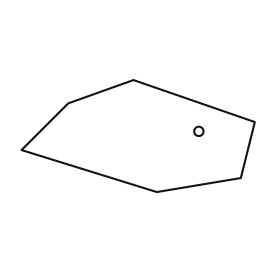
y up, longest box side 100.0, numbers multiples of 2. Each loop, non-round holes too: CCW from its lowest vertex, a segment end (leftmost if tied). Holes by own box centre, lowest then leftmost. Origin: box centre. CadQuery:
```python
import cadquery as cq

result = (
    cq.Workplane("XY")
    .moveTo(8.0, -24.0)
    .lineTo(44.0, -18.0)
    .lineTo(50.0, 6.0)
    .lineTo(-2.0, 24.0)
    .lineTo(-30.0, 14.0)
    .lineTo(-50.0, -6.0)
    .close()
    .moveTo(26.0, 2.0)
    .circle(2.0)
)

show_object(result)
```